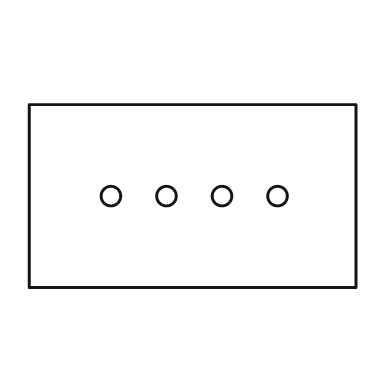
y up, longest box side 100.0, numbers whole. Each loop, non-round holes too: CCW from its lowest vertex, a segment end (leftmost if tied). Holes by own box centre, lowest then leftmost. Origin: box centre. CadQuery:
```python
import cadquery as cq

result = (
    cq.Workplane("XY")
    .moveTo(-50.0, -28.0)
    .lineTo(50.0, -28.0)
    .lineTo(50.0, 28.0)
    .lineTo(-50.0, 28.0)
    .close()
    .moveTo(-25.0, 0.0)
    .circle(3.0)
    .moveTo(-8.0, 0.0)
    .circle(3.0)
    .moveTo(9.0, 0.0)
    .circle(3.0)
    .moveTo(26.0, 0.0)
    .circle(3.0)
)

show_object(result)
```